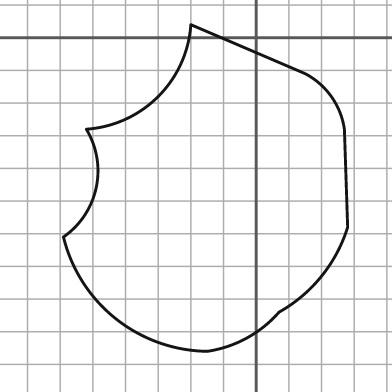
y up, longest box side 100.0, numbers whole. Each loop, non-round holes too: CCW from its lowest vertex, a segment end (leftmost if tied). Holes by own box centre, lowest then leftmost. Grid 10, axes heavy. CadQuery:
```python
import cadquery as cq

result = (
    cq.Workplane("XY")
    .moveTo(-15.0, -96.0)
    .threePointArc((-3.0, -92.0), (7.0, -84.0))
    .threePointArc((20.0, -73.0), (28.0, -58.0))
    .lineTo(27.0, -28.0)
    .threePointArc((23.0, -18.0), (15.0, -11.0))
    .lineTo(-20.0, 4.0)
    .threePointArc((-30.0, -18.0), (-52.0, -28.0))
    .threePointArc((-49.0, -46.0), (-59.0, -61.0))
    .threePointArc((-43.0, -86.0), (-15.0, -96.0))
    .close()
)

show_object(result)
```